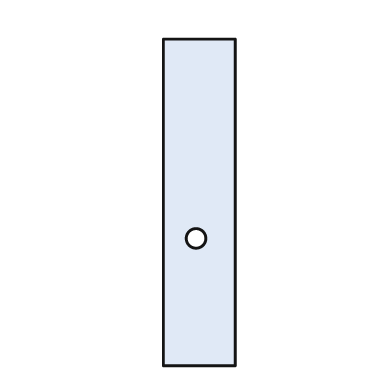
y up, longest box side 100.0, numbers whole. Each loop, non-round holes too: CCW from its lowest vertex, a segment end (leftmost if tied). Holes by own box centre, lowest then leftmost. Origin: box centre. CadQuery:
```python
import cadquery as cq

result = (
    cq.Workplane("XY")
    .moveTo(-11.0, -50.0)
    .lineTo(11.0, -50.0)
    .lineTo(11.0, 50.0)
    .lineTo(-11.0, 50.0)
    .close()
    .moveTo(-1.0, -11.0)
    .circle(3.0)
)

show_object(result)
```